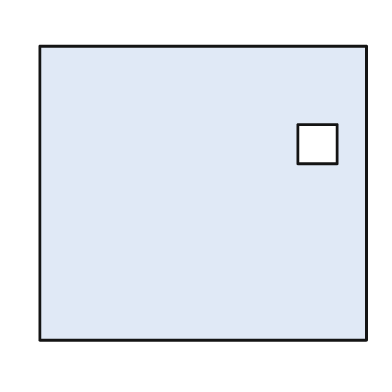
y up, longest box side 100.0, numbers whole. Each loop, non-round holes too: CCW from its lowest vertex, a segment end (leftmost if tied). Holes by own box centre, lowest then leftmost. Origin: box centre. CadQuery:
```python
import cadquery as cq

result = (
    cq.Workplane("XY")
    .moveTo(-50.0, -45.0)
    .lineTo(50.0, -45.0)
    .lineTo(50.0, 45.0)
    .lineTo(-50.0, 45.0)
    .close()
    .moveTo(29.0, 9.0)
    .lineTo(41.0, 9.0)
    .lineTo(41.0, 21.0)
    .lineTo(29.0, 21.0)
    .close()
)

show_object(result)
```